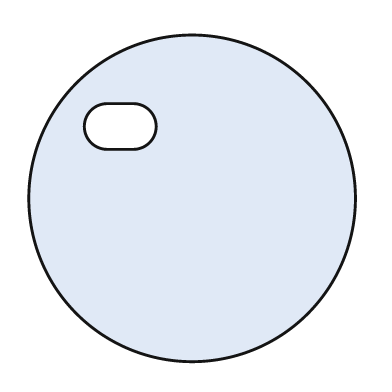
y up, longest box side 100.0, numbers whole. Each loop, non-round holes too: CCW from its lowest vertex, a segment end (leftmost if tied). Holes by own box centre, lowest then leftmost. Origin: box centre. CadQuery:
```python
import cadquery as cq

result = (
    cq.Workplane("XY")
    .moveTo(0.0, 0.0)
    .circle(50.0)
    .moveTo(-26.0, 15.0)
    .lineTo(-18.0, 15.0)
    .threePointArc((-11.0, 22.0), (-18.0, 29.0))
    .lineTo(-26.0, 29.0)
    .threePointArc((-33.0, 22.0), (-26.0, 15.0))
    .close()
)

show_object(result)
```